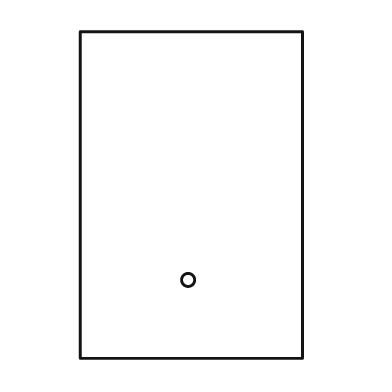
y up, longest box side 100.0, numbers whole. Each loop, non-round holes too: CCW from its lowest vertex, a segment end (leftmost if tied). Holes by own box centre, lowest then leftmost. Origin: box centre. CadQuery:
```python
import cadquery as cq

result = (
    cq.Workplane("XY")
    .moveTo(-34.0, -50.0)
    .lineTo(34.0, -50.0)
    .lineTo(34.0, 50.0)
    .lineTo(-34.0, 50.0)
    .close()
    .moveTo(-1.0, -26.0)
    .circle(2.0)
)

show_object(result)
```